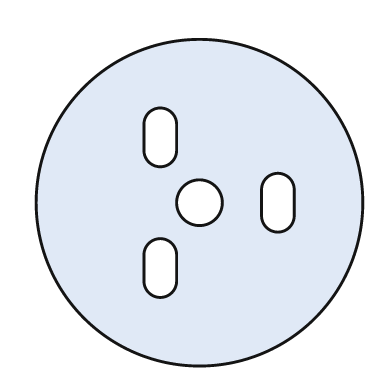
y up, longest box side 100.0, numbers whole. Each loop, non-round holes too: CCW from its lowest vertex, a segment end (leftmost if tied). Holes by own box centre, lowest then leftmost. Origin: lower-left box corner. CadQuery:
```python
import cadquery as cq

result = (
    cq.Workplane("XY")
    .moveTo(50.0, 50.0)
    .circle(50.0)
    .moveTo(33.0, 26.0)
    .threePointArc((38.0, 21.0), (43.0, 26.0))
    .lineTo(43.0, 34.0)
    .threePointArc((38.0, 39.0), (33.0, 34.0))
    .close()
    .moveTo(50.0, 50.0)
    .circle(7.0)
    .moveTo(69.0, 46.0)
    .threePointArc((74.0, 41.0), (79.0, 46.0))
    .lineTo(79.0, 54.0)
    .threePointArc((74.0, 59.0), (69.0, 54.0))
    .close()
    .moveTo(33.0, 66.0)
    .threePointArc((38.0, 61.0), (43.0, 66.0))
    .lineTo(43.0, 74.0)
    .threePointArc((38.0, 79.0), (33.0, 74.0))
    .close()
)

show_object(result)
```